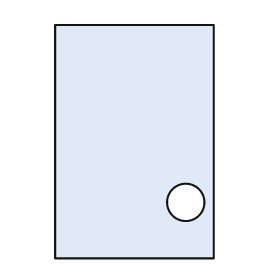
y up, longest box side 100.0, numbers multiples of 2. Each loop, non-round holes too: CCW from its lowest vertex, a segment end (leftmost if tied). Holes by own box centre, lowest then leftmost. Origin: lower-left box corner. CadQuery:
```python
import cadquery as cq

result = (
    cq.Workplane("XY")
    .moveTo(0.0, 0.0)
    .lineTo(68.0, 0.0)
    .lineTo(68.0, 100.0)
    .lineTo(0.0, 100.0)
    .close()
    .moveTo(56.0, 24.0)
    .circle(8.0)
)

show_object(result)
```